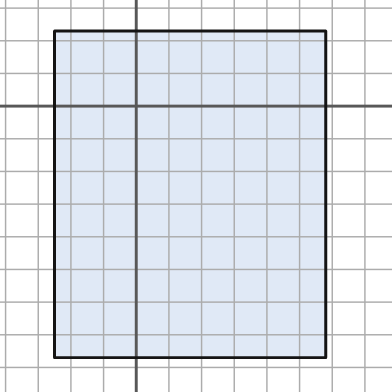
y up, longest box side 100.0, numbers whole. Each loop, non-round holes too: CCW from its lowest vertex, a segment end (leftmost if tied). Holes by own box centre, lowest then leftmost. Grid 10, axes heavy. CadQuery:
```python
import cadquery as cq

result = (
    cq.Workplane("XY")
    .moveTo(-25.0, -77.0)
    .lineTo(58.0, -77.0)
    .lineTo(58.0, 23.0)
    .lineTo(-25.0, 23.0)
    .close()
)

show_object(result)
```